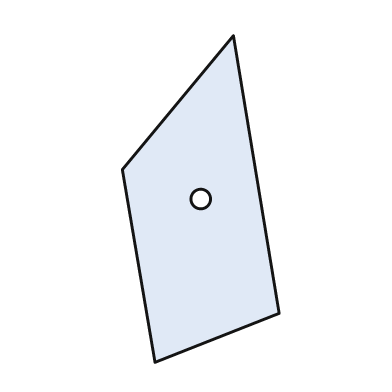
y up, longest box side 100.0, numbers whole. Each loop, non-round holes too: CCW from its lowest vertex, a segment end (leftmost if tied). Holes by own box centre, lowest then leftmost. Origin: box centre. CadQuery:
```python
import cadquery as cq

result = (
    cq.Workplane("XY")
    .moveTo(-14.0, -50.0)
    .lineTo(24.0, -35.0)
    .lineTo(10.0, 50.0)
    .lineTo(-24.0, 9.0)
    .close()
    .moveTo(0.0, 0.0)
    .circle(3.0)
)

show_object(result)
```